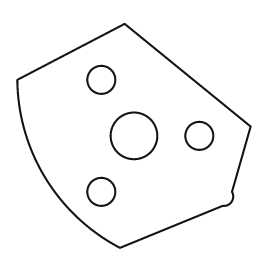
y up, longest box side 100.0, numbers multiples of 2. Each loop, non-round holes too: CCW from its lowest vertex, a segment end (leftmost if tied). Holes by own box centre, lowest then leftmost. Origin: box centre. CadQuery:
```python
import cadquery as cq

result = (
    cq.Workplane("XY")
    .moveTo(-6.0, -48.0)
    .lineTo(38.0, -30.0)
    .threePointArc((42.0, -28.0), (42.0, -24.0))
    .lineTo(50.0, 4.0)
    .lineTo(-4.0, 48.0)
    .lineTo(-50.0, 24.0)
    .threePointArc((-38.0, -18.0), (-6.0, -48.0))
    .close()
    .moveTo(-14.0, -24.0)
    .circle(6.0)
    .moveTo(0.0, 0.0)
    .circle(10.0)
    .moveTo(28.0, 0.0)
    .circle(6.0)
    .moveTo(-14.0, 24.0)
    .circle(6.0)
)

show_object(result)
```